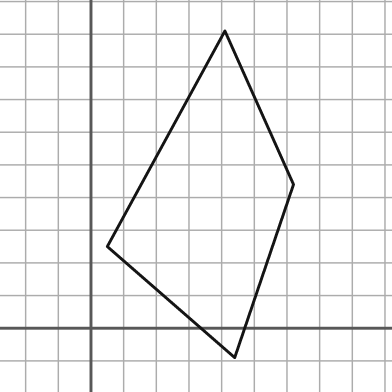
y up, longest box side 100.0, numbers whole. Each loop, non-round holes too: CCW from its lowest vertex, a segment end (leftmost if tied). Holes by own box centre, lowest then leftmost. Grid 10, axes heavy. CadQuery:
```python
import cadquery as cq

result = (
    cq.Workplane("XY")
    .moveTo(44.0, -9.0)
    .lineTo(62.0, 44.0)
    .lineTo(41.0, 91.0)
    .lineTo(5.0, 25.0)
    .close()
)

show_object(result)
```